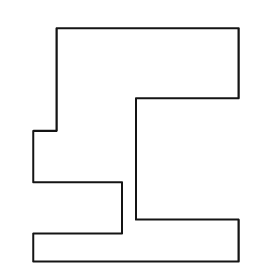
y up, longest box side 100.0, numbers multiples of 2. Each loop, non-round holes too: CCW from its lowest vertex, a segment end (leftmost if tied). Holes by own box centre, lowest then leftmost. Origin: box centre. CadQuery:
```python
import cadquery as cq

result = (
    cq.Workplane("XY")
    .moveTo(-44.0, -50.0)
    .lineTo(44.0, -50.0)
    .lineTo(44.0, -32.0)
    .lineTo(0.0, -32.0)
    .lineTo(0.0, 20.0)
    .lineTo(44.0, 20.0)
    .lineTo(44.0, 50.0)
    .lineTo(-34.0, 50.0)
    .lineTo(-34.0, 6.0)
    .lineTo(-44.0, 6.0)
    .lineTo(-44.0, -16.0)
    .lineTo(-6.0, -16.0)
    .lineTo(-6.0, -38.0)
    .lineTo(-44.0, -38.0)
    .close()
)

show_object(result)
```